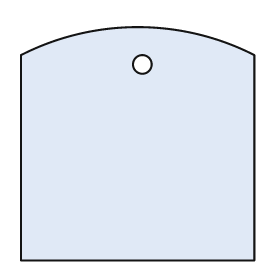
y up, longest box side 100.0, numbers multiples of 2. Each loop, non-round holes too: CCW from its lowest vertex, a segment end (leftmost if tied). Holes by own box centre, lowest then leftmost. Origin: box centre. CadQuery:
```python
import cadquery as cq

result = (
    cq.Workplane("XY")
    .moveTo(-50.0, -50.0)
    .lineTo(50.0, -50.0)
    .lineTo(50.0, 38.0)
    .threePointArc((0.0, 50.0), (-50.0, 38.0))
    .close()
    .moveTo(2.0, 34.0)
    .circle(4.0)
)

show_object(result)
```